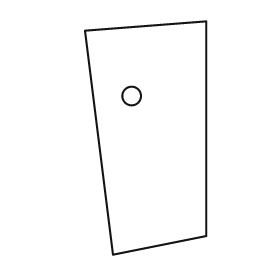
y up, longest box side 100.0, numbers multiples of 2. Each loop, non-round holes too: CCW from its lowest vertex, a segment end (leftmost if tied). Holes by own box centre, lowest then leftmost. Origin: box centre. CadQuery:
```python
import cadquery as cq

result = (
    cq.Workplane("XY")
    .moveTo(-14.0, -50.0)
    .lineTo(26.0, -42.0)
    .lineTo(26.0, 50.0)
    .lineTo(-26.0, 46.0)
    .close()
    .moveTo(-6.0, 18.0)
    .circle(4.0)
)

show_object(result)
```